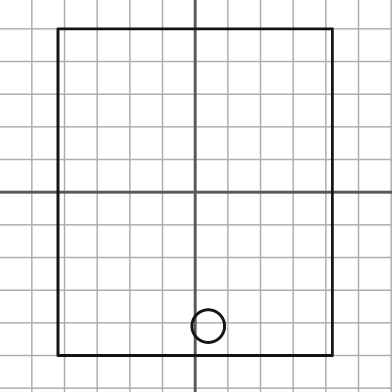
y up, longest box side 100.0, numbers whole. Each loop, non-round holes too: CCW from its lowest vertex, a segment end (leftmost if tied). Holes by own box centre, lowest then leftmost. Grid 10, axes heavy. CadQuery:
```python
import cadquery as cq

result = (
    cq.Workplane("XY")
    .moveTo(-42.0, -50.0)
    .lineTo(42.0, -50.0)
    .lineTo(42.0, 50.0)
    .lineTo(-42.0, 50.0)
    .close()
    .moveTo(4.0, -41.0)
    .circle(5.0)
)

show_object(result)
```